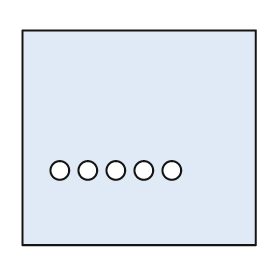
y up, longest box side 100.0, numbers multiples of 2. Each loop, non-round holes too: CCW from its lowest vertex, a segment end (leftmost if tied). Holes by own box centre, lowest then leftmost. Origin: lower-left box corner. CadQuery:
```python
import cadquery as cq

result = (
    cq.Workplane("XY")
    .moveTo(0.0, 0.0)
    .lineTo(100.0, 0.0)
    .lineTo(100.0, 92.0)
    .lineTo(0.0, 92.0)
    .close()
    .moveTo(16.0, 32.0)
    .circle(4.0)
    .moveTo(28.0, 32.0)
    .circle(4.0)
    .moveTo(40.0, 32.0)
    .circle(4.0)
    .moveTo(52.0, 32.0)
    .circle(4.0)
    .moveTo(64.0, 32.0)
    .circle(4.0)
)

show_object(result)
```